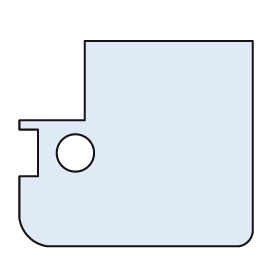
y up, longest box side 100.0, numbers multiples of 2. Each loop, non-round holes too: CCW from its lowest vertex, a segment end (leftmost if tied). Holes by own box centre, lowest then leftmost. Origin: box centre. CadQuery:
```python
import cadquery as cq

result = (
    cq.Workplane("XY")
    .moveTo(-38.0, -44.0)
    .lineTo(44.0, -44.0)
    .threePointArc((48.0, -42.0), (50.0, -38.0))
    .lineTo(50.0, 44.0)
    .lineTo(-22.0, 44.0)
    .lineTo(-22.0, 10.0)
    .lineTo(-50.0, 10.0)
    .lineTo(-50.0, 6.0)
    .lineTo(-42.0, 6.0)
    .lineTo(-42.0, -14.0)
    .lineTo(-50.0, -14.0)
    .lineTo(-50.0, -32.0)
    .threePointArc((-46.0, -40.0), (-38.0, -44.0))
    .close()
    .moveTo(-26.0, -4.0)
    .circle(8.0)
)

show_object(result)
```